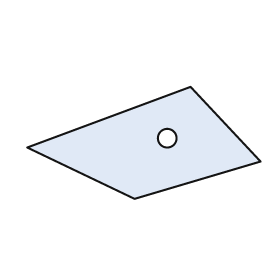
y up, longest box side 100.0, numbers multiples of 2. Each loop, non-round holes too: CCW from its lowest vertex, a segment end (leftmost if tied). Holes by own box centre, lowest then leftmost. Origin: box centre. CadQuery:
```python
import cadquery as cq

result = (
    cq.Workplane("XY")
    .moveTo(-4.0, -24.0)
    .lineTo(50.0, -8.0)
    .lineTo(20.0, 24.0)
    .lineTo(-50.0, -2.0)
    .close()
    .moveTo(10.0, 2.0)
    .circle(4.0)
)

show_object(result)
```